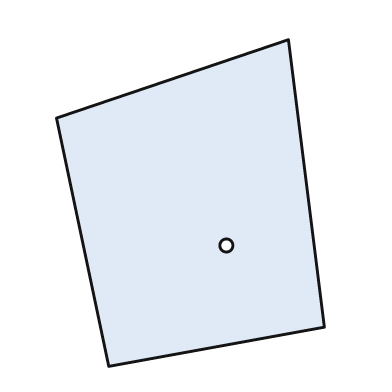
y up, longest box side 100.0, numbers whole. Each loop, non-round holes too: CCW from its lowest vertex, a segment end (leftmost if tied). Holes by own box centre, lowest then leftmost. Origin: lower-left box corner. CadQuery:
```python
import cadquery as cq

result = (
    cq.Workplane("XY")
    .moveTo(16.0, 0.0)
    .lineTo(82.0, 12.0)
    .lineTo(71.0, 100.0)
    .lineTo(0.0, 76.0)
    .close()
    .moveTo(52.0, 37.0)
    .circle(2.0)
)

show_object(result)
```